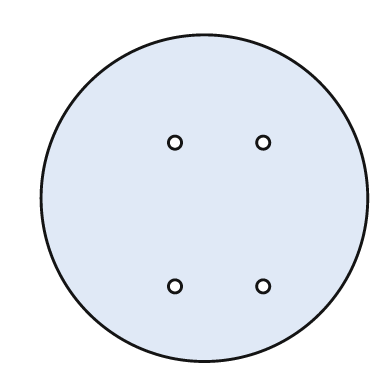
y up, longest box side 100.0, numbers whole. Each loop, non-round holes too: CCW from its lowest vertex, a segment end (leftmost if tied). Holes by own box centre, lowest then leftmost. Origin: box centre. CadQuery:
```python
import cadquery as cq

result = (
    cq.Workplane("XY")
    .moveTo(0.0, 0.0)
    .circle(50.0)
    .moveTo(-9.0, -27.0)
    .circle(2.0)
    .moveTo(18.0, -27.0)
    .circle(2.0)
    .moveTo(-9.0, 17.0)
    .circle(2.0)
    .moveTo(18.0, 17.0)
    .circle(2.0)
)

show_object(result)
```